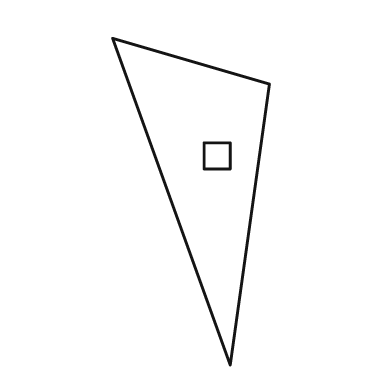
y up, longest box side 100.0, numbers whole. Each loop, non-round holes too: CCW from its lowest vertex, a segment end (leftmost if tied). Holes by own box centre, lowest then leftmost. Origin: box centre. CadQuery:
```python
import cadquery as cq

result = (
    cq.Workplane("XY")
    .moveTo(12.0, -50.0)
    .lineTo(24.0, 36.0)
    .lineTo(-24.0, 50.0)
    .close()
    .moveTo(4.0, 10.0)
    .lineTo(12.0, 10.0)
    .lineTo(12.0, 18.0)
    .lineTo(4.0, 18.0)
    .close()
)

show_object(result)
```